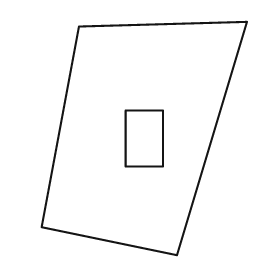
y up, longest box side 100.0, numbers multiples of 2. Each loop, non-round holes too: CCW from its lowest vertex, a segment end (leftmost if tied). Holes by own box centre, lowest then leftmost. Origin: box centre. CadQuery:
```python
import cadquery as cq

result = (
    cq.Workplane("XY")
    .moveTo(14.0, -50.0)
    .lineTo(44.0, 50.0)
    .lineTo(-28.0, 48.0)
    .lineTo(-44.0, -38.0)
    .close()
    .moveTo(-8.0, -12.0)
    .lineTo(8.0, -12.0)
    .lineTo(8.0, 12.0)
    .lineTo(-8.0, 12.0)
    .close()
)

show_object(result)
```